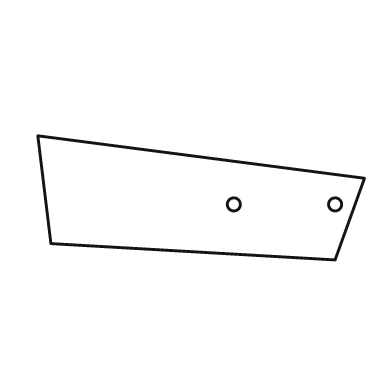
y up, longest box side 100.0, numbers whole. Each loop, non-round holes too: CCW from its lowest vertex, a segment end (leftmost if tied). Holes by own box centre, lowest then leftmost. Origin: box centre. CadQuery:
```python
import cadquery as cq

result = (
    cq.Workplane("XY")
    .moveTo(41.0, -19.0)
    .lineTo(50.0, 6.0)
    .lineTo(-50.0, 19.0)
    .lineTo(-46.0, -14.0)
    .close()
    .moveTo(10.0, -2.0)
    .circle(2.0)
    .moveTo(41.0, -2.0)
    .circle(2.0)
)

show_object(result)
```